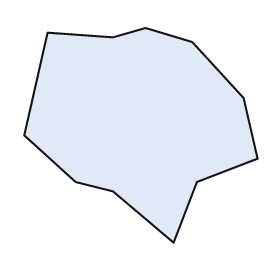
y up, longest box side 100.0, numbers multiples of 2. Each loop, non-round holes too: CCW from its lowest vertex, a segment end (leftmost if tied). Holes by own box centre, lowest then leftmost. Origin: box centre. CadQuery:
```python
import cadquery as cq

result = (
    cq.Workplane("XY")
    .moveTo(14.0, -46.0)
    .lineTo(24.0, -20.0)
    .lineTo(50.0, -10.0)
    .lineTo(44.0, 16.0)
    .lineTo(22.0, 40.0)
    .lineTo(2.0, 46.0)
    .lineTo(-12.0, 42.0)
    .lineTo(-40.0, 44.0)
    .lineTo(-50.0, 0.0)
    .lineTo(-28.0, -20.0)
    .lineTo(-12.0, -24.0)
    .close()
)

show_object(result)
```